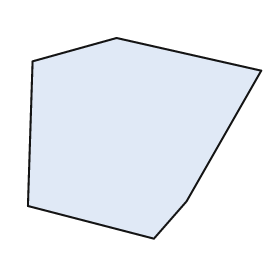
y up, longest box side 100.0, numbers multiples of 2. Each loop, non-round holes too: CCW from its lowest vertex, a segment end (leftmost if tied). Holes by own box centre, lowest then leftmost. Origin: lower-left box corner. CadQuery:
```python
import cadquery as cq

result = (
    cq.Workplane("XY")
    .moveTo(54.0, 0.0)
    .lineTo(68.0, 16.0)
    .lineTo(100.0, 72.0)
    .lineTo(38.0, 86.0)
    .lineTo(2.0, 76.0)
    .lineTo(0.0, 14.0)
    .close()
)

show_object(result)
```